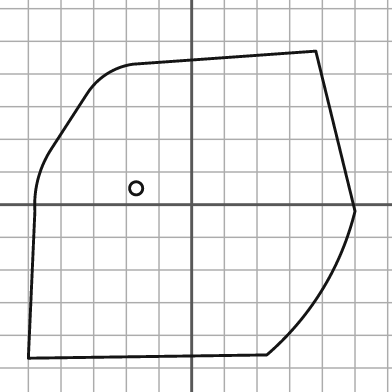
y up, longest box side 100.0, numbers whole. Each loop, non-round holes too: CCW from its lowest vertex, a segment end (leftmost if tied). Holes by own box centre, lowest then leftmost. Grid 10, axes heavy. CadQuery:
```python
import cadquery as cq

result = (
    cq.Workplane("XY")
    .moveTo(-50.0, -47.0)
    .lineTo(23.0, -46.0)
    .threePointArc((40.0, -26.0), (50.0, -2.0))
    .lineTo(38.0, 47.0)
    .lineTo(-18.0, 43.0)
    .threePointArc((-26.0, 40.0), (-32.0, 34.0))
    .lineTo(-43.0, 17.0)
    .threePointArc((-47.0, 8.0), (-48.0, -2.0))
    .close()
    .moveTo(-17.0, 5.0)
    .circle(2.0)
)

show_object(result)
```